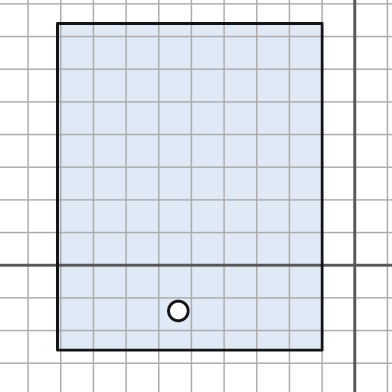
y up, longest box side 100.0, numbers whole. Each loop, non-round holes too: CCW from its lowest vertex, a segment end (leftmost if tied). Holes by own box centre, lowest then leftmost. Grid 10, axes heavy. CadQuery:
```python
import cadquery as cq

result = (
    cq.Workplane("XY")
    .moveTo(-91.0, -26.0)
    .lineTo(-10.0, -26.0)
    .lineTo(-10.0, 74.0)
    .lineTo(-91.0, 74.0)
    .close()
    .moveTo(-54.0, -14.0)
    .circle(3.0)
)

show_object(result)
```